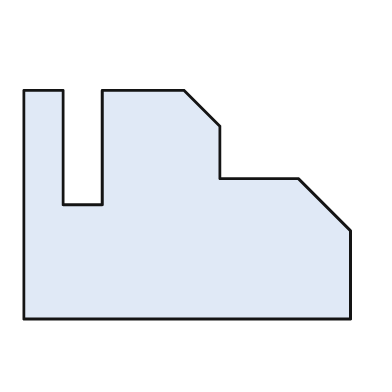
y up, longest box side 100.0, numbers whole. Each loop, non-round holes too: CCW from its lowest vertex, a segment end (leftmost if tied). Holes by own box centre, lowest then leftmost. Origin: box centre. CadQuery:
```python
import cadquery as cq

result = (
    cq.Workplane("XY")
    .moveTo(-50.0, -35.0)
    .lineTo(50.0, -35.0)
    .lineTo(50.0, -8.0)
    .lineTo(34.0, 8.0)
    .lineTo(10.0, 8.0)
    .lineTo(10.0, 24.0)
    .lineTo(-1.0, 35.0)
    .lineTo(-26.0, 35.0)
    .lineTo(-26.0, 0.0)
    .lineTo(-38.0, 0.0)
    .lineTo(-38.0, 35.0)
    .lineTo(-50.0, 35.0)
    .close()
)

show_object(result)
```